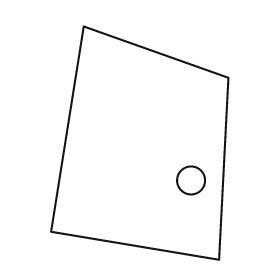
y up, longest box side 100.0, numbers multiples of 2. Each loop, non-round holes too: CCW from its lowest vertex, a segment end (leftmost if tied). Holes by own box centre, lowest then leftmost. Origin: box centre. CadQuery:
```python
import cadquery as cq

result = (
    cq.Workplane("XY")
    .moveTo(34.0, -50.0)
    .lineTo(38.0, 28.0)
    .lineTo(-24.0, 50.0)
    .lineTo(-38.0, -38.0)
    .close()
    .moveTo(22.0, -16.0)
    .circle(6.0)
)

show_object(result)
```